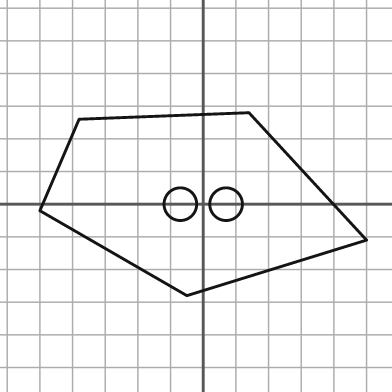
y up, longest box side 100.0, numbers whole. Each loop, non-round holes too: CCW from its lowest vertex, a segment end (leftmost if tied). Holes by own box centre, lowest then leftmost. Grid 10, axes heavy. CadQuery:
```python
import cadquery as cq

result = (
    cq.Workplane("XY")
    .moveTo(-5.0, -28.0)
    .lineTo(50.0, -11.0)
    .lineTo(14.0, 28.0)
    .lineTo(-38.0, 26.0)
    .lineTo(-50.0, -2.0)
    .close()
    .moveTo(-7.0, 0.0)
    .circle(5.0)
    .moveTo(7.0, 0.0)
    .circle(5.0)
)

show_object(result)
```